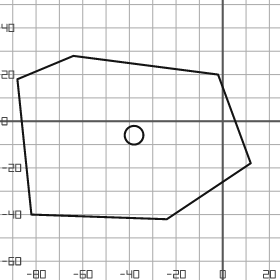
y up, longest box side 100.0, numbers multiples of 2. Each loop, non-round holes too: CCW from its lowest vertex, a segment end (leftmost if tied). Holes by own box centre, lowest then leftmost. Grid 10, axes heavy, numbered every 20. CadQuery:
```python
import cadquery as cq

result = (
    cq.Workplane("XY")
    .moveTo(-24.0, -42.0)
    .lineTo(12.0, -18.0)
    .lineTo(-2.0, 20.0)
    .lineTo(-64.0, 28.0)
    .lineTo(-88.0, 18.0)
    .lineTo(-82.0, -40.0)
    .close()
    .moveTo(-38.0, -6.0)
    .circle(4.0)
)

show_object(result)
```